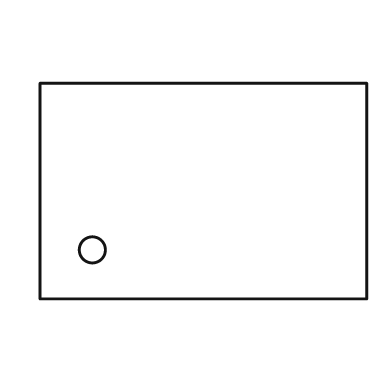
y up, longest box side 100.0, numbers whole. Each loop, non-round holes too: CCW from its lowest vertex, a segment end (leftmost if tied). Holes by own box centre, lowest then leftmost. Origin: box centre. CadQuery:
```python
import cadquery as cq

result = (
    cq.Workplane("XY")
    .moveTo(-50.0, -33.0)
    .lineTo(50.0, -33.0)
    .lineTo(50.0, 33.0)
    .lineTo(-50.0, 33.0)
    .close()
    .moveTo(-34.0, -18.0)
    .circle(4.0)
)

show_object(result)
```